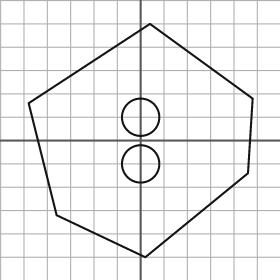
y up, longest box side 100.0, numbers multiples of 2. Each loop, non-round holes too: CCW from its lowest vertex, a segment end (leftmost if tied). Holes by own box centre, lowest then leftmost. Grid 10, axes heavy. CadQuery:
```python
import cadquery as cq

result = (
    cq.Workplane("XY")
    .moveTo(2.0, -50.0)
    .lineTo(46.0, -14.0)
    .lineTo(48.0, 18.0)
    .lineTo(4.0, 50.0)
    .lineTo(-48.0, 16.0)
    .lineTo(-36.0, -32.0)
    .close()
    .moveTo(0.0, -10.0)
    .circle(8.0)
    .moveTo(0.0, 10.0)
    .circle(8.0)
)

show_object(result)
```